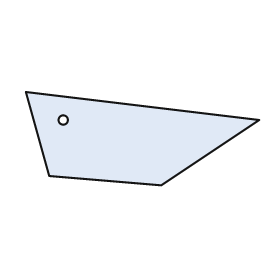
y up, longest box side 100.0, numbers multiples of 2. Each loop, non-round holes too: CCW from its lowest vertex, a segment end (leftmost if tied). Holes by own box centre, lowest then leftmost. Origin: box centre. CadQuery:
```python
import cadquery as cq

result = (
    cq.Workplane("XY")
    .moveTo(8.0, -20.0)
    .lineTo(50.0, 8.0)
    .lineTo(-50.0, 20.0)
    .lineTo(-40.0, -16.0)
    .close()
    .moveTo(-34.0, 8.0)
    .circle(2.0)
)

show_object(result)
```